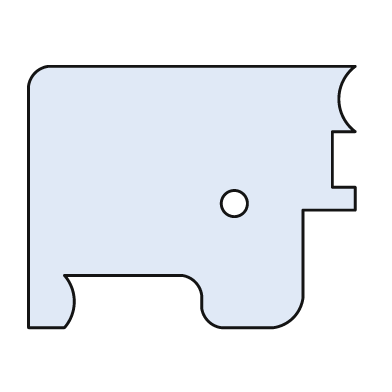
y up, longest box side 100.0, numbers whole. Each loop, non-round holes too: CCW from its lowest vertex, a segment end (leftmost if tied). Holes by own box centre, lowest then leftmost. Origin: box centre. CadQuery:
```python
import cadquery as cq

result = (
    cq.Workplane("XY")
    .moveTo(-50.0, -40.0)
    .lineTo(-39.0, -40.0)
    .threePointArc((-36.0, -32.0), (-39.0, -24.0))
    .lineTo(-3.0, -24.0)
    .threePointArc((1.0, -26.0), (3.0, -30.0))
    .lineTo(3.0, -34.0)
    .threePointArc((5.0, -38.0), (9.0, -40.0))
    .lineTo(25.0, -40.0)
    .threePointArc((31.0, -37.0), (34.0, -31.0))
    .lineTo(34.0, -4.0)
    .lineTo(50.0, -4.0)
    .lineTo(50.0, 3.0)
    .lineTo(43.0, 3.0)
    .lineTo(43.0, 20.0)
    .lineTo(50.0, 20.0)
    .threePointArc((45.0, 30.0), (50.0, 40.0))
    .lineTo(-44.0, 40.0)
    .threePointArc((-48.0, 38.0), (-50.0, 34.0))
    .close()
    .moveTo(13.0, -2.0)
    .circle(4.0)
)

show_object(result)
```